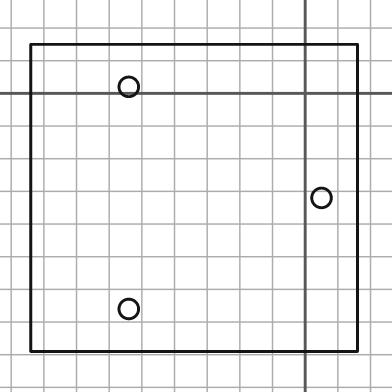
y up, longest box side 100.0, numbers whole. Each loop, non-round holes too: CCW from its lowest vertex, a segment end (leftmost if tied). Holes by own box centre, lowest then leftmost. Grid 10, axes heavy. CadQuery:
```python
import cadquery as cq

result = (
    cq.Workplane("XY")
    .moveTo(-84.0, -79.0)
    .lineTo(16.0, -79.0)
    .lineTo(16.0, 15.0)
    .lineTo(-84.0, 15.0)
    .close()
    .moveTo(-54.0, -66.0)
    .circle(3.0)
    .moveTo(5.0, -32.0)
    .circle(3.0)
    .moveTo(-54.0, 2.0)
    .circle(3.0)
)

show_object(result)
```